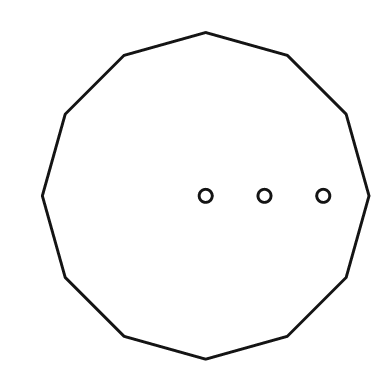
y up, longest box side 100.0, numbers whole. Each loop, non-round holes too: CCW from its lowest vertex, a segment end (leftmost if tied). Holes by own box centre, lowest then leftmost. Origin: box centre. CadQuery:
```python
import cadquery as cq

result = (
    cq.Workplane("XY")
    .moveTo(0.0, -50.0)
    .lineTo(25.0, -43.0)
    .lineTo(43.0, -25.0)
    .lineTo(50.0, 0.0)
    .lineTo(43.0, 25.0)
    .lineTo(25.0, 43.0)
    .lineTo(0.0, 50.0)
    .lineTo(-25.0, 43.0)
    .lineTo(-43.0, 25.0)
    .lineTo(-50.0, 0.0)
    .lineTo(-43.0, -25.0)
    .lineTo(-25.0, -43.0)
    .close()
    .moveTo(0.0, 0.0)
    .circle(2.0)
    .moveTo(18.0, 0.0)
    .circle(2.0)
    .moveTo(36.0, 0.0)
    .circle(2.0)
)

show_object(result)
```